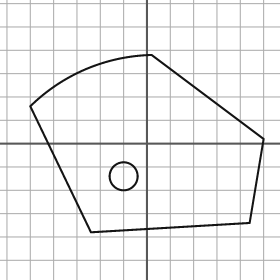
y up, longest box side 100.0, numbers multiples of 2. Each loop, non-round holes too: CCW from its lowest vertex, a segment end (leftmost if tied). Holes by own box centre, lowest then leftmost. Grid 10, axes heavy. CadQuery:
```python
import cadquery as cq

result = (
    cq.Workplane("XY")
    .moveTo(-24.0, -38.0)
    .lineTo(44.0, -34.0)
    .lineTo(50.0, 2.0)
    .lineTo(2.0, 38.0)
    .threePointArc((-26.0, 32.0), (-50.0, 16.0))
    .close()
    .moveTo(-10.0, -14.0)
    .circle(6.0)
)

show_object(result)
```